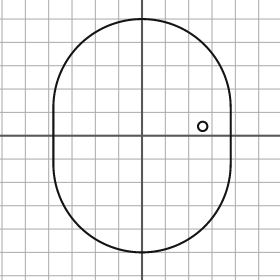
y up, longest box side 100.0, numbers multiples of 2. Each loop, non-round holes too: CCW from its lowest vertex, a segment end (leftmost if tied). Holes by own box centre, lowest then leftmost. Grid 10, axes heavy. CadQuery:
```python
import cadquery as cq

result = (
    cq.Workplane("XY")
    .moveTo(-38.0, -12.0)
    .threePointArc((0.0, -50.0), (38.0, -12.0))
    .lineTo(38.0, 12.0)
    .threePointArc((0.0, 50.0), (-38.0, 12.0))
    .close()
    .moveTo(26.0, 4.0)
    .circle(2.0)
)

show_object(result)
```